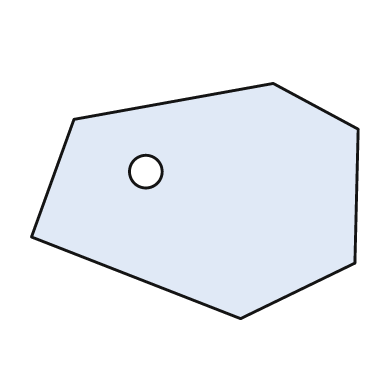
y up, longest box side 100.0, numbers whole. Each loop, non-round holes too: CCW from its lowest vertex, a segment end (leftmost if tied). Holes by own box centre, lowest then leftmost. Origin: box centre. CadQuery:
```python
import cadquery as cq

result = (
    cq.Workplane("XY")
    .moveTo(14.0, -36.0)
    .lineTo(49.0, -19.0)
    .lineTo(50.0, 22.0)
    .lineTo(24.0, 36.0)
    .lineTo(-37.0, 25.0)
    .lineTo(-50.0, -11.0)
    .close()
    .moveTo(-15.0, 9.0)
    .circle(5.0)
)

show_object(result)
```